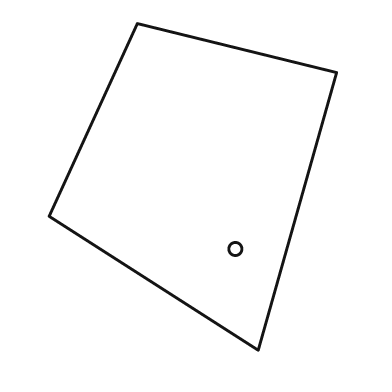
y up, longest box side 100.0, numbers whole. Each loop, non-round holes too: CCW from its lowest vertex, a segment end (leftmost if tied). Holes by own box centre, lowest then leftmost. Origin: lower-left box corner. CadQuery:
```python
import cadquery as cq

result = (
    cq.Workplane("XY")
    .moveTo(64.0, 0.0)
    .lineTo(88.0, 85.0)
    .lineTo(27.0, 100.0)
    .lineTo(0.0, 41.0)
    .close()
    .moveTo(57.0, 31.0)
    .circle(2.0)
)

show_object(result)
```